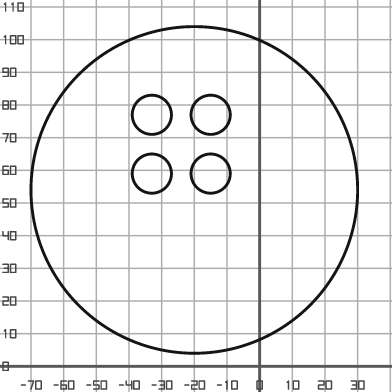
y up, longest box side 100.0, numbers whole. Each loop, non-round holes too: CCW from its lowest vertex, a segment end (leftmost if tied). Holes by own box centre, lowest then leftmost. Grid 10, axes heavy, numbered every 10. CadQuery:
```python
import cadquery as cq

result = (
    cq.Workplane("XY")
    .moveTo(-20.0, 54.0)
    .circle(50.0)
    .moveTo(-33.0, 59.0)
    .circle(6.0)
    .moveTo(-15.0, 59.0)
    .circle(6.0)
    .moveTo(-33.0, 77.0)
    .circle(6.0)
    .moveTo(-15.0, 77.0)
    .circle(6.0)
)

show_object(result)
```